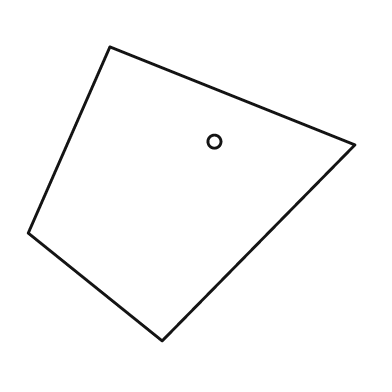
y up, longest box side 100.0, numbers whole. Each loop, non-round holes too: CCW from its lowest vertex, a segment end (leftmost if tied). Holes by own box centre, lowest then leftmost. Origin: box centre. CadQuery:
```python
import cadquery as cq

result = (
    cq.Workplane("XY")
    .moveTo(-9.0, -45.0)
    .lineTo(50.0, 15.0)
    .lineTo(-25.0, 45.0)
    .lineTo(-50.0, -12.0)
    .close()
    .moveTo(7.0, 16.0)
    .circle(2.0)
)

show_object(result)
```